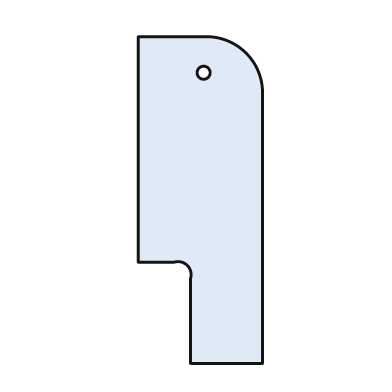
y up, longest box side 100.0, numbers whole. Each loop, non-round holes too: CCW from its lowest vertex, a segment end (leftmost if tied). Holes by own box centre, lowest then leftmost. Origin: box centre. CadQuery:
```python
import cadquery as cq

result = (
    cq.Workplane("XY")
    .moveTo(-3.0, -50.0)
    .lineTo(19.0, -50.0)
    .lineTo(19.0, 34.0)
    .threePointArc((14.0, 45.0), (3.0, 50.0))
    .lineTo(-19.0, 50.0)
    .lineTo(-19.0, -19.0)
    .lineTo(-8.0, -19.0)
    .threePointArc((-4.0, -20.0), (-3.0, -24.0))
    .close()
    .moveTo(1.0, 39.0)
    .circle(2.0)
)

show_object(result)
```